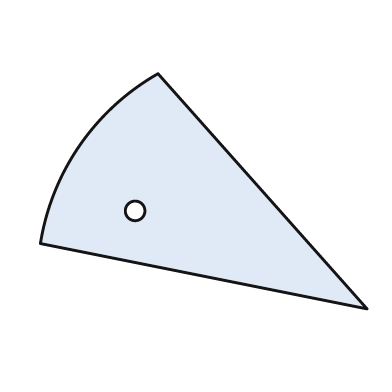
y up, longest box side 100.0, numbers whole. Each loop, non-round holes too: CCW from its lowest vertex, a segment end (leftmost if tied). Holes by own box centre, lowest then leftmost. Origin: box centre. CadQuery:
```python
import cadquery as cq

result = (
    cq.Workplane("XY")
    .moveTo(50.0, -36.0)
    .lineTo(-14.0, 36.0)
    .threePointArc((-38.0, 14.0), (-50.0, -16.0))
    .close()
    .moveTo(-21.0, -6.0)
    .circle(3.0)
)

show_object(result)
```